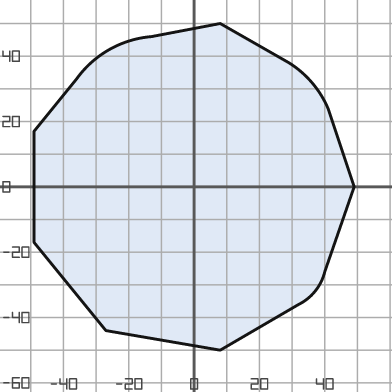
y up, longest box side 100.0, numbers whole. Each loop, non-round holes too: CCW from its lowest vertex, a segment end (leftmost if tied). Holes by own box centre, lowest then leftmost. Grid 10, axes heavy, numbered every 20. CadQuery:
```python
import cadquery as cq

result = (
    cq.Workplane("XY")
    .moveTo(8.0, -50.0)
    .lineTo(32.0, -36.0)
    .threePointArc((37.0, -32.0), (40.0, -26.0))
    .lineTo(49.0, 0.0)
    .lineTo(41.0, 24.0)
    .threePointArc((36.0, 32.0), (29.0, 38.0))
    .lineTo(8.0, 50.0)
    .lineTo(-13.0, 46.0)
    .threePointArc((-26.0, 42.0), (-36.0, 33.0))
    .lineTo(-49.0, 17.0)
    .lineTo(-49.0, -17.0)
    .lineTo(-27.0, -44.0)
    .close()
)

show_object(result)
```